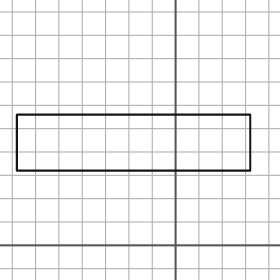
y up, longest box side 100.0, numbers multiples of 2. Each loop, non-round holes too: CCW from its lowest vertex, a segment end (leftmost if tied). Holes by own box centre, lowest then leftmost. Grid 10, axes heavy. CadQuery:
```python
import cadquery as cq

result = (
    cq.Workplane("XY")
    .moveTo(-68.0, 32.0)
    .lineTo(32.0, 32.0)
    .lineTo(32.0, 56.0)
    .lineTo(-68.0, 56.0)
    .close()
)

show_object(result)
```